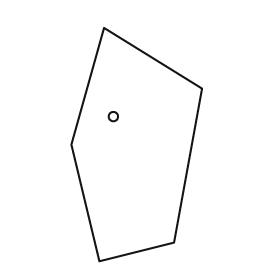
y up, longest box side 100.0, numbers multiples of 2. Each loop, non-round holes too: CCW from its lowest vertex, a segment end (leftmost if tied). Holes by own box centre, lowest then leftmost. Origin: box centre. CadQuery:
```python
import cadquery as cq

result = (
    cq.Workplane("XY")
    .moveTo(-16.0, -50.0)
    .lineTo(16.0, -42.0)
    .lineTo(28.0, 24.0)
    .lineTo(-14.0, 50.0)
    .lineTo(-28.0, 0.0)
    .close()
    .moveTo(-10.0, 12.0)
    .circle(2.0)
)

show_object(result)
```